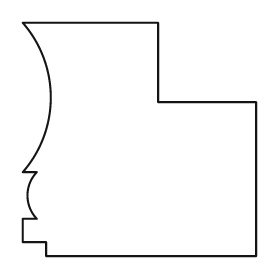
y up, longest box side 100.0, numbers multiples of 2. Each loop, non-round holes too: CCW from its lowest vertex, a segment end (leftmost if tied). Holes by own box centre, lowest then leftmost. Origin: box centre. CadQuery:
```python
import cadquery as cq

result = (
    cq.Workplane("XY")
    .moveTo(-40.0, -50.0)
    .lineTo(50.0, -50.0)
    .lineTo(50.0, 16.0)
    .lineTo(8.0, 16.0)
    .lineTo(8.0, 50.0)
    .lineTo(-50.0, 50.0)
    .threePointArc((-38.0, 18.0), (-50.0, -14.0))
    .lineTo(-44.0, -14.0)
    .threePointArc((-48.0, -24.0), (-44.0, -34.0))
    .lineTo(-50.0, -34.0)
    .lineTo(-50.0, -44.0)
    .lineTo(-40.0, -44.0)
    .close()
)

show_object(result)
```